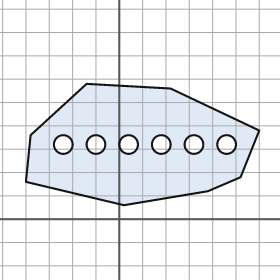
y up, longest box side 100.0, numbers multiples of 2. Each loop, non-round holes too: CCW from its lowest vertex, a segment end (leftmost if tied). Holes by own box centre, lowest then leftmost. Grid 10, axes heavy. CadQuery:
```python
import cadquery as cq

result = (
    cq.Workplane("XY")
    .moveTo(2.0, 6.0)
    .lineTo(38.0, 12.0)
    .lineTo(52.0, 18.0)
    .lineTo(60.0, 38.0)
    .lineTo(22.0, 56.0)
    .lineTo(-14.0, 58.0)
    .lineTo(-38.0, 36.0)
    .lineTo(-40.0, 16.0)
    .close()
    .moveTo(-24.0, 32.0)
    .circle(4.0)
    .moveTo(-10.0, 32.0)
    .circle(4.0)
    .moveTo(4.0, 32.0)
    .circle(4.0)
    .moveTo(18.0, 32.0)
    .circle(4.0)
    .moveTo(32.0, 32.0)
    .circle(4.0)
    .moveTo(46.0, 32.0)
    .circle(4.0)
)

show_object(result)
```